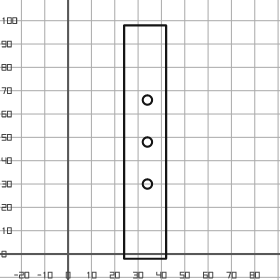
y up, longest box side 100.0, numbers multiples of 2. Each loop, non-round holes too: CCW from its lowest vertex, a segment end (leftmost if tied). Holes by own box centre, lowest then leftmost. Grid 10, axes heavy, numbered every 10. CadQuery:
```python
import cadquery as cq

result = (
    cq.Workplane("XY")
    .moveTo(24.0, -2.0)
    .lineTo(42.0, -2.0)
    .lineTo(42.0, 98.0)
    .lineTo(24.0, 98.0)
    .close()
    .moveTo(34.0, 30.0)
    .circle(2.0)
    .moveTo(34.0, 48.0)
    .circle(2.0)
    .moveTo(34.0, 66.0)
    .circle(2.0)
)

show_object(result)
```